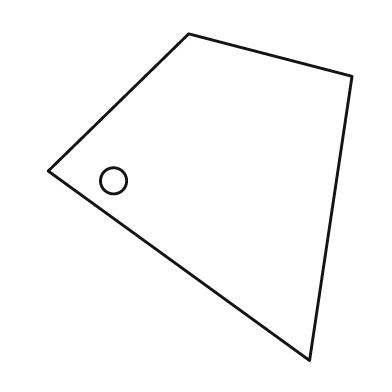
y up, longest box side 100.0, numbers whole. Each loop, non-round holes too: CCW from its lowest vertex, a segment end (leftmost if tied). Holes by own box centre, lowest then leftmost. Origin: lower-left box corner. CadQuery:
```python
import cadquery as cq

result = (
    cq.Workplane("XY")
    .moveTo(80.0, 0.0)
    .lineTo(93.0, 87.0)
    .lineTo(43.0, 100.0)
    .lineTo(0.0, 58.0)
    .close()
    .moveTo(20.0, 55.0)
    .circle(4.0)
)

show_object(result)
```